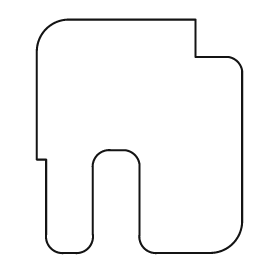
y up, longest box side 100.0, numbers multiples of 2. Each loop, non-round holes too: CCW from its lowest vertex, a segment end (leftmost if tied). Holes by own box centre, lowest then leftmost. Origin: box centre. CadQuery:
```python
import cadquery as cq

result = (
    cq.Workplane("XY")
    .moveTo(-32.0, -50.0)
    .lineTo(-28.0, -50.0)
    .threePointArc((-22.0, -48.0), (-20.0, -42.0))
    .lineTo(-20.0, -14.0)
    .threePointArc((-18.0, -8.0), (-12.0, -6.0))
    .lineTo(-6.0, -6.0)
    .threePointArc((-2.0, -8.0), (0.0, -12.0))
    .lineTo(0.0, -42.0)
    .threePointArc((2.0, -48.0), (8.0, -50.0))
    .lineTo(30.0, -50.0)
    .threePointArc((40.0, -46.0), (44.0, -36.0))
    .lineTo(44.0, 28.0)
    .threePointArc((42.0, 32.0), (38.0, 34.0))
    .lineTo(24.0, 34.0)
    .lineTo(24.0, 50.0)
    .lineTo(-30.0, 50.0)
    .threePointArc((-40.0, 46.0), (-44.0, 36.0))
    .lineTo(-44.0, -10.0)
    .lineTo(-40.0, -10.0)
    .lineTo(-40.0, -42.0)
    .threePointArc((-38.0, -48.0), (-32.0, -50.0))
    .close()
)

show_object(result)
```